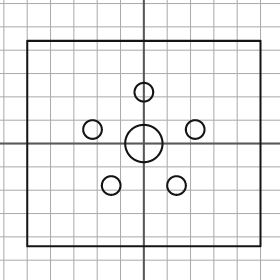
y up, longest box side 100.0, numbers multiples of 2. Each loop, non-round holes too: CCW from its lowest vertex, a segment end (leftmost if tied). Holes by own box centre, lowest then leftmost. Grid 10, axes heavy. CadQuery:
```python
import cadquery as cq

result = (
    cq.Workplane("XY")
    .moveTo(-50.0, -44.0)
    .lineTo(50.0, -44.0)
    .lineTo(50.0, 44.0)
    .lineTo(-50.0, 44.0)
    .close()
    .moveTo(-14.0, -18.0)
    .circle(4.0)
    .moveTo(14.0, -18.0)
    .circle(4.0)
    .moveTo(0.0, 0.0)
    .circle(8.0)
    .moveTo(-22.0, 6.0)
    .circle(4.0)
    .moveTo(22.0, 6.0)
    .circle(4.0)
    .moveTo(0.0, 22.0)
    .circle(4.0)
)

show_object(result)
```